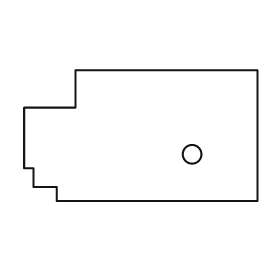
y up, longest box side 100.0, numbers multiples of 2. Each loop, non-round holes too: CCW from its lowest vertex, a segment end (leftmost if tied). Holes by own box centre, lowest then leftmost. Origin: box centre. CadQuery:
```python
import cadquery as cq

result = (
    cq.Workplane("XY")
    .moveTo(-36.0, -28.0)
    .lineTo(50.0, -28.0)
    .lineTo(50.0, 28.0)
    .lineTo(-28.0, 28.0)
    .lineTo(-28.0, 12.0)
    .lineTo(-50.0, 12.0)
    .lineTo(-50.0, -14.0)
    .lineTo(-46.0, -14.0)
    .lineTo(-46.0, -22.0)
    .lineTo(-36.0, -22.0)
    .close()
    .moveTo(22.0, -8.0)
    .circle(4.0)
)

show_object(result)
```